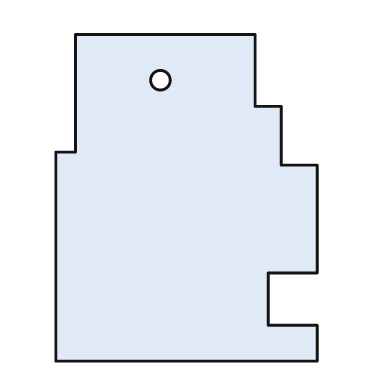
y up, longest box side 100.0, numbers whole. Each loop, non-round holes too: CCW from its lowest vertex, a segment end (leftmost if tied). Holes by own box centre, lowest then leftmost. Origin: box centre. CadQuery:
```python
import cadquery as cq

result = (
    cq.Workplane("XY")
    .moveTo(-40.0, -50.0)
    .lineTo(40.0, -50.0)
    .lineTo(40.0, -39.0)
    .lineTo(25.0, -39.0)
    .lineTo(25.0, -23.0)
    .lineTo(40.0, -23.0)
    .lineTo(40.0, 10.0)
    .lineTo(29.0, 10.0)
    .lineTo(29.0, 28.0)
    .lineTo(21.0, 28.0)
    .lineTo(21.0, 50.0)
    .lineTo(-34.0, 50.0)
    .lineTo(-34.0, 14.0)
    .lineTo(-40.0, 14.0)
    .close()
    .moveTo(-8.0, 36.0)
    .circle(3.0)
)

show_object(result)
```